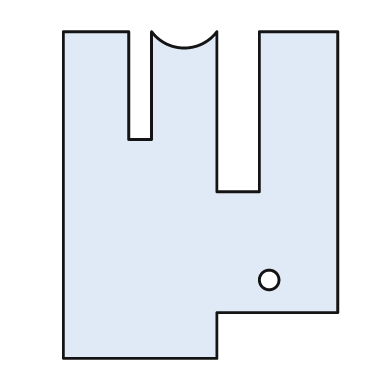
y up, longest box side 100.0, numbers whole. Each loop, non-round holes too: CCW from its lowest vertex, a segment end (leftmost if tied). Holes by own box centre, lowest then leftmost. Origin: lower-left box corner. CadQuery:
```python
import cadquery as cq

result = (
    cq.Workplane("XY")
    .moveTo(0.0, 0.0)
    .lineTo(47.0, 0.0)
    .lineTo(47.0, 14.0)
    .lineTo(84.0, 14.0)
    .lineTo(84.0, 100.0)
    .lineTo(60.0, 100.0)
    .lineTo(60.0, 51.0)
    .lineTo(47.0, 51.0)
    .lineTo(47.0, 100.0)
    .threePointArc((37.0, 95.0), (27.0, 100.0))
    .lineTo(27.0, 67.0)
    .lineTo(20.0, 67.0)
    .lineTo(20.0, 100.0)
    .lineTo(0.0, 100.0)
    .close()
    .moveTo(63.0, 24.0)
    .circle(3.0)
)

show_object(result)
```